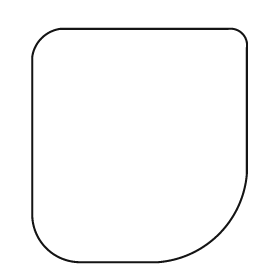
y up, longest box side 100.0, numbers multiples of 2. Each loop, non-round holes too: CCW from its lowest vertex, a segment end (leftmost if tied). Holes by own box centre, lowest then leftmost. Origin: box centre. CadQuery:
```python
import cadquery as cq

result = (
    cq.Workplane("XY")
    .moveTo(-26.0, -50.0)
    .lineTo(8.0, -50.0)
    .threePointArc((34.0, -38.0), (46.0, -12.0))
    .lineTo(46.0, 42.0)
    .threePointArc((44.0, 48.0), (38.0, 50.0))
    .lineTo(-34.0, 50.0)
    .threePointArc((-42.0, 46.0), (-46.0, 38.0))
    .lineTo(-46.0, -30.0)
    .threePointArc((-40.0, -44.0), (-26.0, -50.0))
    .close()
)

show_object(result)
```